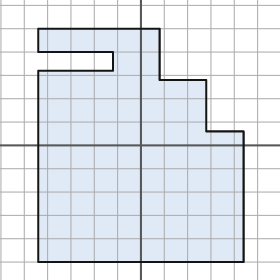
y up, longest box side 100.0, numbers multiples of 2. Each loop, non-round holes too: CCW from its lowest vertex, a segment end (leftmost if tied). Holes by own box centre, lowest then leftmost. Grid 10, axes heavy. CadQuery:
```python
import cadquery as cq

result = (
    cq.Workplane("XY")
    .moveTo(-44.0, -50.0)
    .lineTo(44.0, -50.0)
    .lineTo(44.0, 6.0)
    .lineTo(28.0, 6.0)
    .lineTo(28.0, 28.0)
    .lineTo(8.0, 28.0)
    .lineTo(8.0, 50.0)
    .lineTo(-44.0, 50.0)
    .lineTo(-44.0, 40.0)
    .lineTo(-12.0, 40.0)
    .lineTo(-12.0, 32.0)
    .lineTo(-44.0, 32.0)
    .close()
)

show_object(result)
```